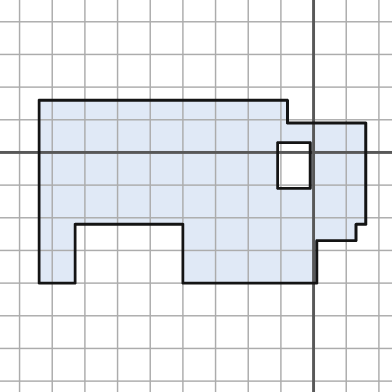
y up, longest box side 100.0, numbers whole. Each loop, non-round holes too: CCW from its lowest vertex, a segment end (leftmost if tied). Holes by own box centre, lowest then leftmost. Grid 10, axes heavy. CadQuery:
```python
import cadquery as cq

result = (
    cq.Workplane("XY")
    .moveTo(-84.0, -40.0)
    .lineTo(-73.0, -40.0)
    .lineTo(-73.0, -22.0)
    .lineTo(-40.0, -22.0)
    .lineTo(-40.0, -40.0)
    .lineTo(1.0, -40.0)
    .lineTo(1.0, -27.0)
    .lineTo(13.0, -27.0)
    .lineTo(13.0, -22.0)
    .lineTo(16.0, -22.0)
    .lineTo(16.0, 9.0)
    .lineTo(-8.0, 9.0)
    .lineTo(-8.0, 16.0)
    .lineTo(-84.0, 16.0)
    .close()
    .moveTo(-11.0, -11.0)
    .lineTo(-1.0, -11.0)
    .lineTo(-1.0, 3.0)
    .lineTo(-11.0, 3.0)
    .close()
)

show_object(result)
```